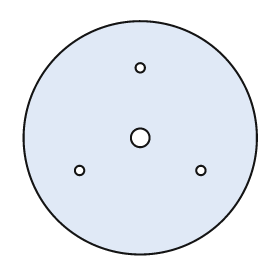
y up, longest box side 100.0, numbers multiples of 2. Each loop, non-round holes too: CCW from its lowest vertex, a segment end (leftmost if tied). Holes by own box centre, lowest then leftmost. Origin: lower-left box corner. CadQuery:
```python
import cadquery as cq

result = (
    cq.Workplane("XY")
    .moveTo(50.0, 50.0)
    .circle(50.0)
    .moveTo(24.0, 36.0)
    .circle(2.0)
    .moveTo(76.0, 36.0)
    .circle(2.0)
    .moveTo(50.0, 50.0)
    .circle(4.0)
    .moveTo(50.0, 80.0)
    .circle(2.0)
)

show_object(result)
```